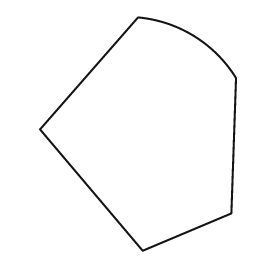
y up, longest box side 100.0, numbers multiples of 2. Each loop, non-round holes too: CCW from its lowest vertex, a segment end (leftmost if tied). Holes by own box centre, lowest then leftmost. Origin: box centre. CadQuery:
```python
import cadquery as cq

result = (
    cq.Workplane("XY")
    .moveTo(2.0, -50.0)
    .lineTo(40.0, -34.0)
    .lineTo(42.0, 24.0)
    .threePointArc((24.0, 42.0), (0.0, 50.0))
    .lineTo(-42.0, 2.0)
    .close()
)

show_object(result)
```